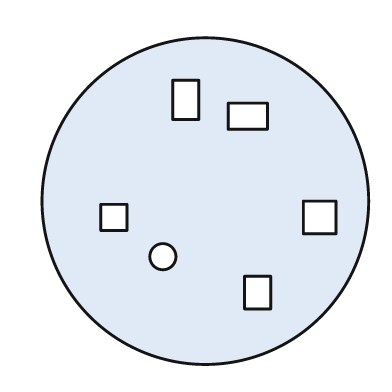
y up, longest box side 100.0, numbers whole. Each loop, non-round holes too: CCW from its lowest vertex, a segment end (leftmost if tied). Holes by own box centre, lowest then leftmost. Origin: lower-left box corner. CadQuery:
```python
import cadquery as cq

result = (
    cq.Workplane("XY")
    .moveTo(50.0, 50.0)
    .circle(50.0)
    .moveTo(62.0, 17.0)
    .lineTo(70.0, 17.0)
    .lineTo(70.0, 27.0)
    .lineTo(62.0, 27.0)
    .close()
    .moveTo(37.0, 33.0)
    .circle(4.0)
    .moveTo(18.0, 41.0)
    .lineTo(26.0, 41.0)
    .lineTo(26.0, 49.0)
    .lineTo(18.0, 49.0)
    .close()
    .moveTo(80.0, 40.0)
    .lineTo(90.0, 40.0)
    .lineTo(90.0, 50.0)
    .lineTo(80.0, 50.0)
    .close()
    .moveTo(57.0, 72.0)
    .lineTo(69.0, 72.0)
    .lineTo(69.0, 80.0)
    .lineTo(57.0, 80.0)
    .close()
    .moveTo(40.0, 75.0)
    .lineTo(48.0, 75.0)
    .lineTo(48.0, 87.0)
    .lineTo(40.0, 87.0)
    .close()
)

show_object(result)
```